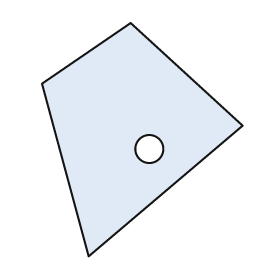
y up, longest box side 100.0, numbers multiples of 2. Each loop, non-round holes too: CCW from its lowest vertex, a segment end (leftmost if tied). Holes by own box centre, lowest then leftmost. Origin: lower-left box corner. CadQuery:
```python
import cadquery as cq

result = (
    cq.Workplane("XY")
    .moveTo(20.0, 0.0)
    .lineTo(86.0, 56.0)
    .lineTo(38.0, 100.0)
    .lineTo(0.0, 74.0)
    .close()
    .moveTo(46.0, 46.0)
    .circle(6.0)
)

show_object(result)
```